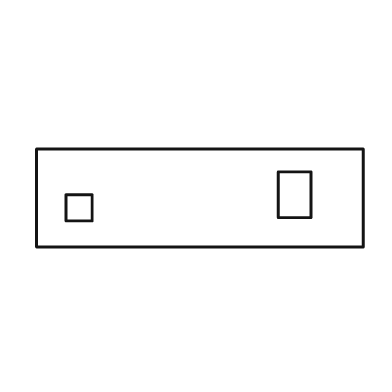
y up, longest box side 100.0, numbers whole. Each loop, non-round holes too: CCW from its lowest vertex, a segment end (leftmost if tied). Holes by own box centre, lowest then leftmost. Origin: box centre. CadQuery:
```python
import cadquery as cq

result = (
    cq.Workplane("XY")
    .moveTo(-50.0, -15.0)
    .lineTo(50.0, -15.0)
    .lineTo(50.0, 15.0)
    .lineTo(-50.0, 15.0)
    .close()
    .moveTo(-41.0, -7.0)
    .lineTo(-33.0, -7.0)
    .lineTo(-33.0, 1.0)
    .lineTo(-41.0, 1.0)
    .close()
    .moveTo(24.0, -6.0)
    .lineTo(34.0, -6.0)
    .lineTo(34.0, 8.0)
    .lineTo(24.0, 8.0)
    .close()
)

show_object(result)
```